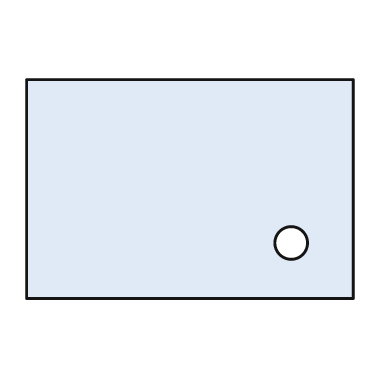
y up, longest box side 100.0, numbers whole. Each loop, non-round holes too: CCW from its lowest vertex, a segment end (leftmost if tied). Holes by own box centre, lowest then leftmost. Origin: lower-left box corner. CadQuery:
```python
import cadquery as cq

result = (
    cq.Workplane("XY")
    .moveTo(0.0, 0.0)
    .lineTo(100.0, 0.0)
    .lineTo(100.0, 67.0)
    .lineTo(0.0, 67.0)
    .close()
    .moveTo(81.0, 17.0)
    .circle(5.0)
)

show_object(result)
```